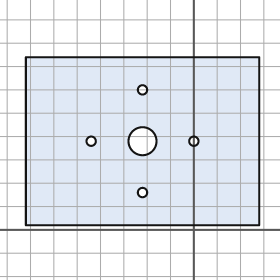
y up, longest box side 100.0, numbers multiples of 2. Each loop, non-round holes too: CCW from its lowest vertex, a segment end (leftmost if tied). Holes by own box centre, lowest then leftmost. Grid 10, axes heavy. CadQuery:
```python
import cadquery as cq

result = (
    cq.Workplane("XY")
    .moveTo(-72.0, 2.0)
    .lineTo(28.0, 2.0)
    .lineTo(28.0, 74.0)
    .lineTo(-72.0, 74.0)
    .close()
    .moveTo(-22.0, 16.0)
    .circle(2.0)
    .moveTo(-44.0, 38.0)
    .circle(2.0)
    .moveTo(-22.0, 38.0)
    .circle(6.0)
    .moveTo(0.0, 38.0)
    .circle(2.0)
    .moveTo(-22.0, 60.0)
    .circle(2.0)
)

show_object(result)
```